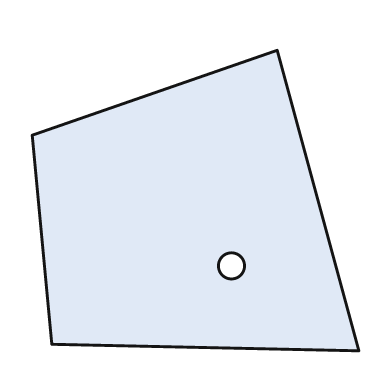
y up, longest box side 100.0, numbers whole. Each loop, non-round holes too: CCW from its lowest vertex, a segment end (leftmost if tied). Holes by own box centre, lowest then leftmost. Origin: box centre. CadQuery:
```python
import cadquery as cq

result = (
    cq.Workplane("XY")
    .moveTo(50.0, -46.0)
    .lineTo(25.0, 46.0)
    .lineTo(-50.0, 20.0)
    .lineTo(-44.0, -44.0)
    .close()
    .moveTo(11.0, -20.0)
    .circle(4.0)
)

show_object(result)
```